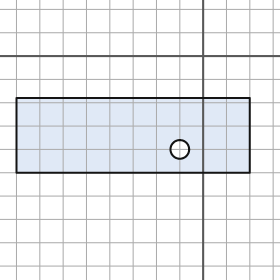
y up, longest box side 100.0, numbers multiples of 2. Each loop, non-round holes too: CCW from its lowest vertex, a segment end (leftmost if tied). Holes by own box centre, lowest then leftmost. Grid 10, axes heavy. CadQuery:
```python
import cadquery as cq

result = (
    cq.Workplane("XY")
    .moveTo(-80.0, -50.0)
    .lineTo(20.0, -50.0)
    .lineTo(20.0, -18.0)
    .lineTo(-80.0, -18.0)
    .close()
    .moveTo(-10.0, -40.0)
    .circle(4.0)
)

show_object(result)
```